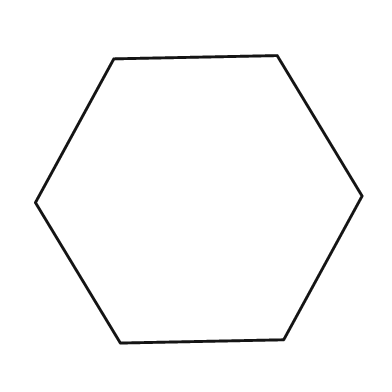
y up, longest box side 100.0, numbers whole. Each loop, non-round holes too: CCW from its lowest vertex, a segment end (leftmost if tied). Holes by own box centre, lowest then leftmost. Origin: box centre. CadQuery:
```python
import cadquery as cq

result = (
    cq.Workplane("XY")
    .moveTo(-24.0, -44.0)
    .lineTo(26.0, -43.0)
    .lineTo(50.0, 1.0)
    .lineTo(24.0, 44.0)
    .lineTo(-26.0, 43.0)
    .lineTo(-50.0, -1.0)
    .close()
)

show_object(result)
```